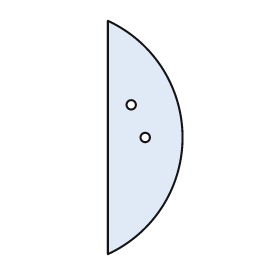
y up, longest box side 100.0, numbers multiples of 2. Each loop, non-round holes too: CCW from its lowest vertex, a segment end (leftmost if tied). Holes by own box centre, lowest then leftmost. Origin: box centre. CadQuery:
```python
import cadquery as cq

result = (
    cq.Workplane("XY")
    .moveTo(-16.0, -50.0)
    .threePointArc((16.0, 0.0), (-16.0, 50.0))
    .close()
    .moveTo(0.0, 0.0)
    .circle(2.0)
    .moveTo(-6.0, 14.0)
    .circle(2.0)
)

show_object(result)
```